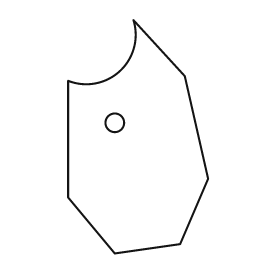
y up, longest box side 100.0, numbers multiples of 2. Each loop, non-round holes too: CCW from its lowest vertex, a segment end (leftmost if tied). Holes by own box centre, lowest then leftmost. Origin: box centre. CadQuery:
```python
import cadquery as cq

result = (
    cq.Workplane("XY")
    .moveTo(-10.0, -50.0)
    .lineTo(18.0, -46.0)
    .lineTo(30.0, -18.0)
    .lineTo(20.0, 26.0)
    .lineTo(-2.0, 50.0)
    .threePointArc((-8.0, 28.0), (-30.0, 24.0))
    .lineTo(-30.0, -26.0)
    .close()
    .moveTo(-10.0, 6.0)
    .circle(4.0)
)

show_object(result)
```